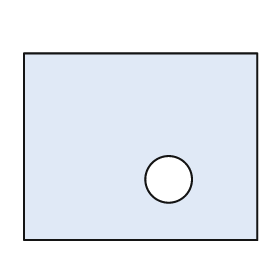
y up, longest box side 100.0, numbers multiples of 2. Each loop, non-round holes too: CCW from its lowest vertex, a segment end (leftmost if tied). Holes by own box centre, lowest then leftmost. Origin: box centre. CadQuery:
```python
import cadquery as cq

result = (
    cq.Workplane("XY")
    .moveTo(-50.0, -40.0)
    .lineTo(50.0, -40.0)
    .lineTo(50.0, 40.0)
    .lineTo(-50.0, 40.0)
    .close()
    .moveTo(12.0, -14.0)
    .circle(10.0)
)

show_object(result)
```